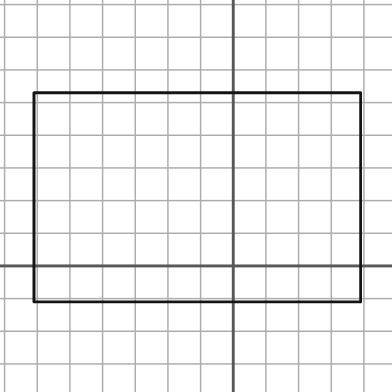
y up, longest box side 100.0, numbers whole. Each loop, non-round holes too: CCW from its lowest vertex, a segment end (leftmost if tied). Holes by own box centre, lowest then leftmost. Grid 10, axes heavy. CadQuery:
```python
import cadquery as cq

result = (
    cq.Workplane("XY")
    .moveTo(-61.0, -11.0)
    .lineTo(39.0, -11.0)
    .lineTo(39.0, 53.0)
    .lineTo(-61.0, 53.0)
    .close()
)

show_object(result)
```